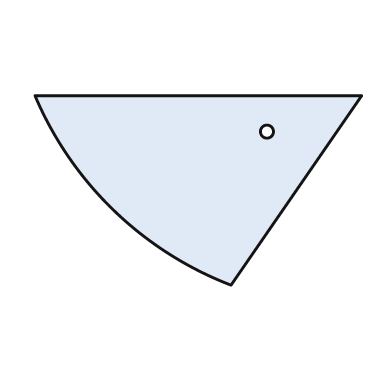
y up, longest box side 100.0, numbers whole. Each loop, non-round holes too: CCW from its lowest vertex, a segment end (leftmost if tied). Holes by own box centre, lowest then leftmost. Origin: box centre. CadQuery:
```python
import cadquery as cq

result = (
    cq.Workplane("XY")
    .moveTo(10.0, -29.0)
    .lineTo(50.0, 29.0)
    .lineTo(-50.0, 29.0)
    .threePointArc((-26.0, -6.0), (10.0, -29.0))
    .close()
    .moveTo(21.0, 18.0)
    .circle(2.0)
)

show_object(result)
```